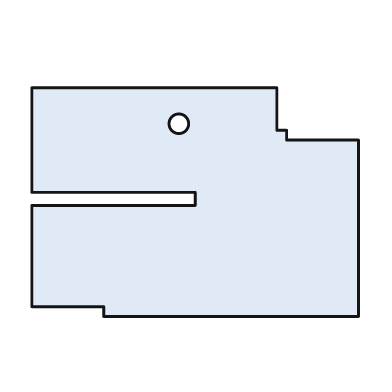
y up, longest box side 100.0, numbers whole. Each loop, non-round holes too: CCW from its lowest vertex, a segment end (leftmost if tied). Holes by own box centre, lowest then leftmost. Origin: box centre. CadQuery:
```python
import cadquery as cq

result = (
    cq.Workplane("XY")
    .moveTo(-28.0, -35.0)
    .lineTo(50.0, -35.0)
    .lineTo(50.0, 19.0)
    .lineTo(28.0, 19.0)
    .lineTo(28.0, 22.0)
    .lineTo(25.0, 22.0)
    .lineTo(25.0, 35.0)
    .lineTo(-50.0, 35.0)
    .lineTo(-50.0, 3.0)
    .lineTo(0.0, 3.0)
    .lineTo(0.0, -1.0)
    .lineTo(-50.0, -1.0)
    .lineTo(-50.0, -32.0)
    .lineTo(-28.0, -32.0)
    .close()
    .moveTo(-5.0, 24.0)
    .circle(3.0)
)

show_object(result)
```